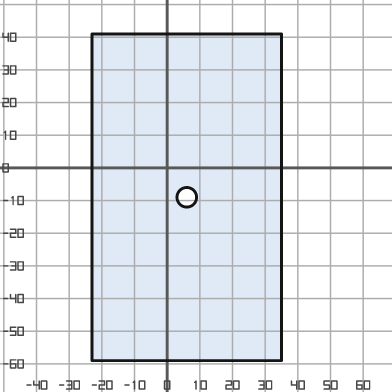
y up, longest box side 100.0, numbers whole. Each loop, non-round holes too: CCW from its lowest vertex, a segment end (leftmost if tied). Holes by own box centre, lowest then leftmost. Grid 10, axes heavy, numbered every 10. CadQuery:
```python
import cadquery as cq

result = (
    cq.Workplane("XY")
    .moveTo(-23.0, -59.0)
    .lineTo(35.0, -59.0)
    .lineTo(35.0, 41.0)
    .lineTo(-23.0, 41.0)
    .close()
    .moveTo(6.0, -9.0)
    .circle(3.0)
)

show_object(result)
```